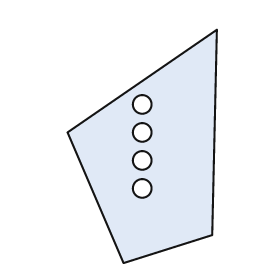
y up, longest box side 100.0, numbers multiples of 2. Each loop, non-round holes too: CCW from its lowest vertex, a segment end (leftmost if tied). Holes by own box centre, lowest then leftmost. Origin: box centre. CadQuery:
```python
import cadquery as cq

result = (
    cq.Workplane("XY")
    .moveTo(-8.0, -50.0)
    .lineTo(30.0, -38.0)
    .lineTo(32.0, 50.0)
    .lineTo(-32.0, 6.0)
    .close()
    .moveTo(0.0, -18.0)
    .circle(4.0)
    .moveTo(0.0, -6.0)
    .circle(4.0)
    .moveTo(0.0, 6.0)
    .circle(4.0)
    .moveTo(0.0, 18.0)
    .circle(4.0)
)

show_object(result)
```